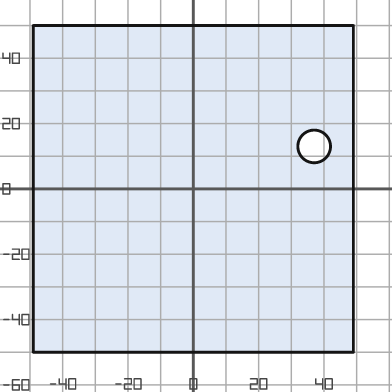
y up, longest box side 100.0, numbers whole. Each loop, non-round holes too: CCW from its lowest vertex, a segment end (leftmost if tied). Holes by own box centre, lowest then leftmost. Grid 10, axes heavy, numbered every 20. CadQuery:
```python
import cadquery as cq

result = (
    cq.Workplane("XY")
    .moveTo(-49.0, -50.0)
    .lineTo(49.0, -50.0)
    .lineTo(49.0, 50.0)
    .lineTo(-49.0, 50.0)
    .close()
    .moveTo(37.0, 13.0)
    .circle(5.0)
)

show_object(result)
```